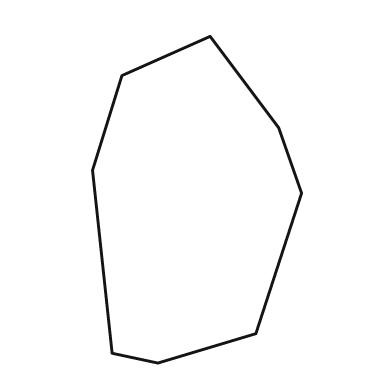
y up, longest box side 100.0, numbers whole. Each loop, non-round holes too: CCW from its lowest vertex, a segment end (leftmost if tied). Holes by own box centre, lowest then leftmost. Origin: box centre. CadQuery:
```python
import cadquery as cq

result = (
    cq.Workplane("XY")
    .moveTo(-12.0, -50.0)
    .lineTo(18.0, -41.0)
    .lineTo(32.0, 2.0)
    .lineTo(25.0, 22.0)
    .lineTo(4.0, 50.0)
    .lineTo(-23.0, 38.0)
    .lineTo(-32.0, 9.0)
    .lineTo(-26.0, -47.0)
    .close()
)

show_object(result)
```